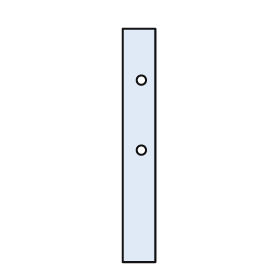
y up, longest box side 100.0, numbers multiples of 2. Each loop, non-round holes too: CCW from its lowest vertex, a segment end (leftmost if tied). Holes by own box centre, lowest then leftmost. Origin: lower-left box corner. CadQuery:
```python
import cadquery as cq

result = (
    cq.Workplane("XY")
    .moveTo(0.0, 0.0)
    .lineTo(14.0, 0.0)
    .lineTo(14.0, 100.0)
    .lineTo(0.0, 100.0)
    .close()
    .moveTo(8.0, 48.0)
    .circle(2.0)
    .moveTo(8.0, 78.0)
    .circle(2.0)
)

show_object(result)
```